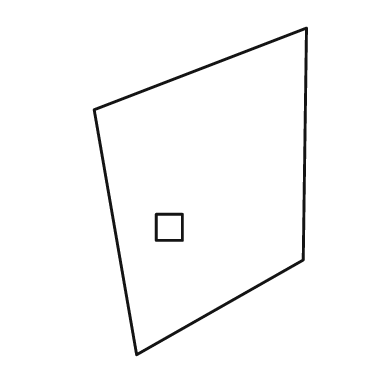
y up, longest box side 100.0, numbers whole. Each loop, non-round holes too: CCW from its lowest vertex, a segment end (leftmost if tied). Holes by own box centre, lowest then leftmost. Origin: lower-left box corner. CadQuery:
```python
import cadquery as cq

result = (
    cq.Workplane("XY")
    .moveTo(13.0, 0.0)
    .lineTo(64.0, 29.0)
    .lineTo(65.0, 100.0)
    .lineTo(0.0, 75.0)
    .close()
    .moveTo(19.0, 35.0)
    .lineTo(27.0, 35.0)
    .lineTo(27.0, 43.0)
    .lineTo(19.0, 43.0)
    .close()
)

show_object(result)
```